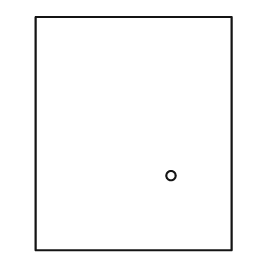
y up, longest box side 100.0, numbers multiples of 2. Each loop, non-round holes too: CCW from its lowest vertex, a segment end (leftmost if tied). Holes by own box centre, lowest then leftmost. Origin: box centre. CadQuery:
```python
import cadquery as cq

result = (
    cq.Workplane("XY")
    .moveTo(-42.0, -50.0)
    .lineTo(42.0, -50.0)
    .lineTo(42.0, 50.0)
    .lineTo(-42.0, 50.0)
    .close()
    .moveTo(16.0, -18.0)
    .circle(2.0)
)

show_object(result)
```